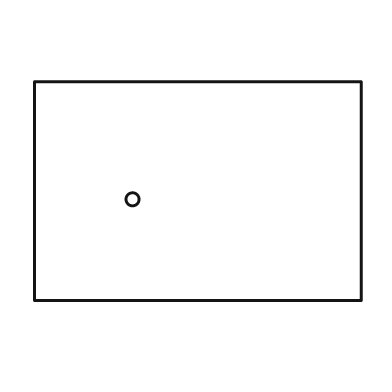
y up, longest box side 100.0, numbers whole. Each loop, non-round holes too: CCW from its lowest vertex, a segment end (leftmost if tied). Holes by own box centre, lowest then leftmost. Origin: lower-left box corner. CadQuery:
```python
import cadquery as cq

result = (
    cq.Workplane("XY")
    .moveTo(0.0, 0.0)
    .lineTo(100.0, 0.0)
    .lineTo(100.0, 67.0)
    .lineTo(0.0, 67.0)
    .close()
    .moveTo(30.0, 31.0)
    .circle(2.0)
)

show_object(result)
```